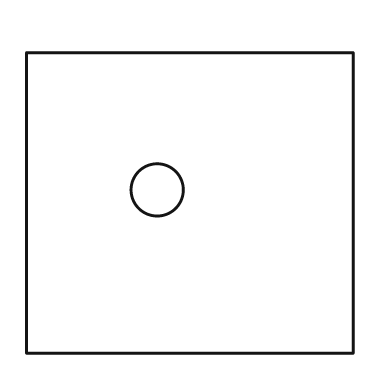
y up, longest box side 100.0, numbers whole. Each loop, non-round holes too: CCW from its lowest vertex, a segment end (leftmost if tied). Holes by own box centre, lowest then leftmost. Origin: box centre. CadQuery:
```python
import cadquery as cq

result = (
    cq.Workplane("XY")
    .moveTo(-50.0, -46.0)
    .lineTo(50.0, -46.0)
    .lineTo(50.0, 46.0)
    .lineTo(-50.0, 46.0)
    .close()
    .moveTo(-10.0, 4.0)
    .circle(8.0)
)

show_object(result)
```